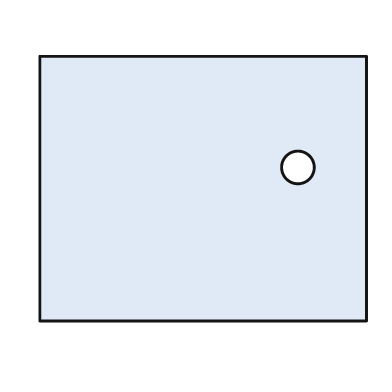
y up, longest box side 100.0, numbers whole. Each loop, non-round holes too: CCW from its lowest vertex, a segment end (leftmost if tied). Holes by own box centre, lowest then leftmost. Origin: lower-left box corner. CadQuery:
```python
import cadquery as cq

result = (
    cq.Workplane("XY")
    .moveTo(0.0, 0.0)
    .lineTo(100.0, 0.0)
    .lineTo(100.0, 81.0)
    .lineTo(0.0, 81.0)
    .close()
    .moveTo(79.0, 47.0)
    .circle(5.0)
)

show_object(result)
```